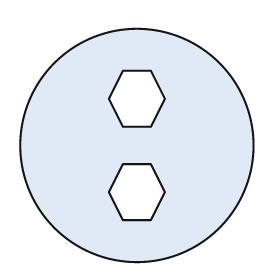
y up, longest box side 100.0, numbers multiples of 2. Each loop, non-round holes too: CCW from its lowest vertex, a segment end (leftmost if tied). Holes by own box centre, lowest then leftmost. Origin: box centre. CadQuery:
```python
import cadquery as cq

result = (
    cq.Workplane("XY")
    .moveTo(0.0, 0.0)
    .circle(50.0)
    .moveTo(-6.0, -32.0)
    .lineTo(6.0, -32.0)
    .lineTo(12.0, -20.0)
    .lineTo(6.0, -8.0)
    .lineTo(-6.0, -8.0)
    .lineTo(-12.0, -20.0)
    .close()
    .moveTo(-6.0, 8.0)
    .lineTo(6.0, 8.0)
    .lineTo(12.0, 20.0)
    .lineTo(6.0, 32.0)
    .lineTo(-6.0, 32.0)
    .lineTo(-12.0, 20.0)
    .close()
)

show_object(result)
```